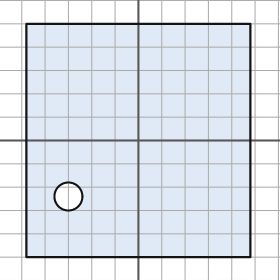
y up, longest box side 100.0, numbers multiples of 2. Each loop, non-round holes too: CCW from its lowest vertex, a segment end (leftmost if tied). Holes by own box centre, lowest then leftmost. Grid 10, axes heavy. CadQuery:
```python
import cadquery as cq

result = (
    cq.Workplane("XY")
    .moveTo(-48.0, -50.0)
    .lineTo(48.0, -50.0)
    .lineTo(48.0, 50.0)
    .lineTo(-48.0, 50.0)
    .close()
    .moveTo(-30.0, -24.0)
    .circle(6.0)
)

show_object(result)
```